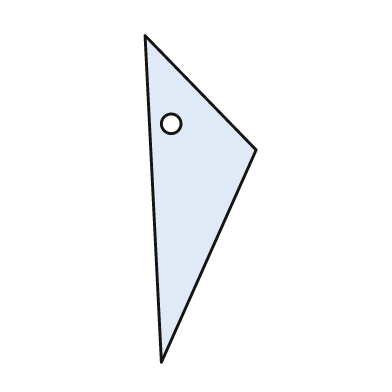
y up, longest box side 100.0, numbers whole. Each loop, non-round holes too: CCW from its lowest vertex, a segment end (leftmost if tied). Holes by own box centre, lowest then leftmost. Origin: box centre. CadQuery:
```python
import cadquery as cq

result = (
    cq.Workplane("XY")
    .moveTo(-12.0, -50.0)
    .lineTo(17.0, 15.0)
    .lineTo(-17.0, 50.0)
    .close()
    .moveTo(-9.0, 23.0)
    .circle(3.0)
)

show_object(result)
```